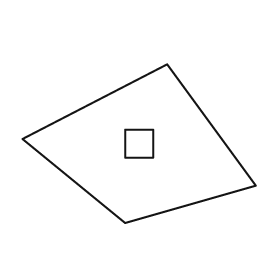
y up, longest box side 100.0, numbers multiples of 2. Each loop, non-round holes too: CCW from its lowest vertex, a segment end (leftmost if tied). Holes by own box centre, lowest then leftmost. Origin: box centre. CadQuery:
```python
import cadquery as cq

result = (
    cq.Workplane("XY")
    .moveTo(-6.0, -34.0)
    .lineTo(50.0, -18.0)
    .lineTo(12.0, 34.0)
    .lineTo(-50.0, 2.0)
    .close()
    .moveTo(-6.0, -6.0)
    .lineTo(6.0, -6.0)
    .lineTo(6.0, 6.0)
    .lineTo(-6.0, 6.0)
    .close()
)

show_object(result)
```